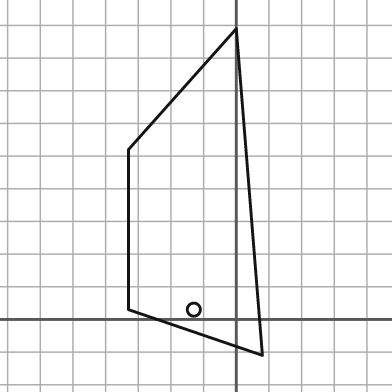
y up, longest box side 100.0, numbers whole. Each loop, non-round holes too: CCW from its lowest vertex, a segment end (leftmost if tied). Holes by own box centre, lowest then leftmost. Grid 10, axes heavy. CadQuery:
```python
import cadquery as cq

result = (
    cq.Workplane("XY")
    .moveTo(8.0, -11.0)
    .lineTo(0.0, 89.0)
    .lineTo(-33.0, 52.0)
    .lineTo(-33.0, 3.0)
    .close()
    .moveTo(-13.0, 3.0)
    .circle(2.0)
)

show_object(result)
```